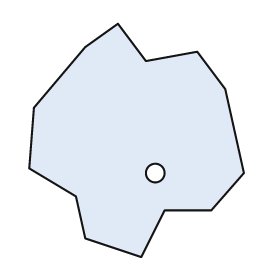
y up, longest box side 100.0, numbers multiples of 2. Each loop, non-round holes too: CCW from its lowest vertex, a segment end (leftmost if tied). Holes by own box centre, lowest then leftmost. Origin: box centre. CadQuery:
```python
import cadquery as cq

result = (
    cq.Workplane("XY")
    .moveTo(2.0, -50.0)
    .lineTo(12.0, -30.0)
    .lineTo(32.0, -30.0)
    .lineTo(46.0, -14.0)
    .lineTo(38.0, 22.0)
    .lineTo(26.0, 38.0)
    .lineTo(4.0, 34.0)
    .lineTo(-8.0, 50.0)
    .lineTo(-22.0, 40.0)
    .lineTo(-44.0, 14.0)
    .lineTo(-46.0, -12.0)
    .lineTo(-26.0, -24.0)
    .lineTo(-22.0, -42.0)
    .close()
    .moveTo(8.0, -14.0)
    .circle(4.0)
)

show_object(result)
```